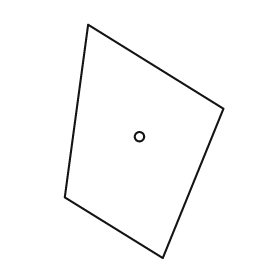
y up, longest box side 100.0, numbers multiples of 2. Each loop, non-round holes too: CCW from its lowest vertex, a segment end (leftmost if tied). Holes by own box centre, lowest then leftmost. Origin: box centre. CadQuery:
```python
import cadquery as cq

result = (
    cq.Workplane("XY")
    .moveTo(8.0, -50.0)
    .lineTo(34.0, 14.0)
    .lineTo(-24.0, 50.0)
    .lineTo(-34.0, -24.0)
    .close()
    .moveTo(-2.0, 2.0)
    .circle(2.0)
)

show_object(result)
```